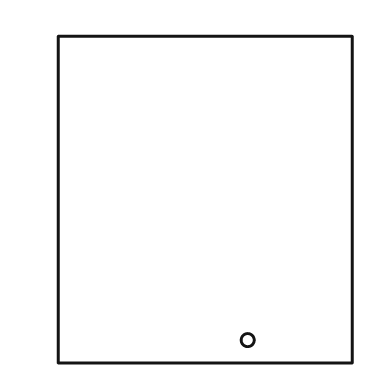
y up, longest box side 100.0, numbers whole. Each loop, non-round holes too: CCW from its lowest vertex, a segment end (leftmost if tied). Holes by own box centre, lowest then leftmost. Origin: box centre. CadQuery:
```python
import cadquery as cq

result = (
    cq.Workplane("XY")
    .moveTo(-45.0, -50.0)
    .lineTo(45.0, -50.0)
    .lineTo(45.0, 50.0)
    .lineTo(-45.0, 50.0)
    .close()
    .moveTo(13.0, -43.0)
    .circle(2.0)
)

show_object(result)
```